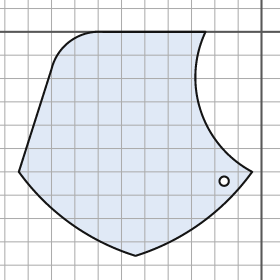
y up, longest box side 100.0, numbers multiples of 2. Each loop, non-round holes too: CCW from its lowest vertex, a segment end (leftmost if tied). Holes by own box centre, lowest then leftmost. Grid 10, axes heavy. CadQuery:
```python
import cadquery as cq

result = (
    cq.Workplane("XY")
    .moveTo(-54.0, -96.0)
    .threePointArc((-26.0, -82.0), (-4.0, -60.0))
    .threePointArc((-26.0, -34.0), (-24.0, 0.0))
    .lineTo(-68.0, 0.0)
    .threePointArc((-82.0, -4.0), (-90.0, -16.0))
    .lineTo(-104.0, -60.0)
    .threePointArc((-82.0, -82.0), (-54.0, -96.0))
    .close()
    .moveTo(-16.0, -64.0)
    .circle(2.0)
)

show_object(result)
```